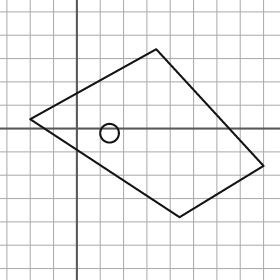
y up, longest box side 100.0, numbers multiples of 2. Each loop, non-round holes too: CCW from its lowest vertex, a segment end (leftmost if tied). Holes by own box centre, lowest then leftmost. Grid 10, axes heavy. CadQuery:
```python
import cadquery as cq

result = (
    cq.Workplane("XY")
    .moveTo(44.0, -38.0)
    .lineTo(80.0, -16.0)
    .lineTo(34.0, 34.0)
    .lineTo(-20.0, 4.0)
    .close()
    .moveTo(14.0, -2.0)
    .circle(4.0)
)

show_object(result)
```